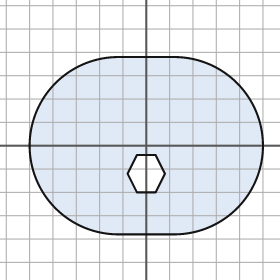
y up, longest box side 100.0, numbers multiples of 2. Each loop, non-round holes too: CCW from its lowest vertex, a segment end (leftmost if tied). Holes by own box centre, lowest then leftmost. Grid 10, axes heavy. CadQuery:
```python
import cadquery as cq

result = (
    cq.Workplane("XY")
    .moveTo(-12.0, -38.0)
    .lineTo(12.0, -38.0)
    .threePointArc((50.0, 0.0), (12.0, 38.0))
    .lineTo(-12.0, 38.0)
    .threePointArc((-50.0, 0.0), (-12.0, -38.0))
    .close()
    .moveTo(-4.0, -20.0)
    .lineTo(4.0, -20.0)
    .lineTo(8.0, -12.0)
    .lineTo(4.0, -4.0)
    .lineTo(-4.0, -4.0)
    .lineTo(-8.0, -12.0)
    .close()
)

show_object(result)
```